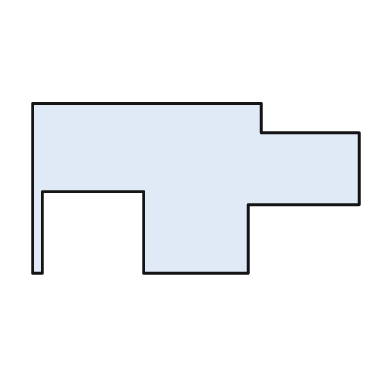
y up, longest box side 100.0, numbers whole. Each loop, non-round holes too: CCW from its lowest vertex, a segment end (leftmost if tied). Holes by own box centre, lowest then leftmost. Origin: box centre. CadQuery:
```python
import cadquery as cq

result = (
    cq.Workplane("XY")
    .moveTo(-50.0, -26.0)
    .lineTo(-47.0, -26.0)
    .lineTo(-47.0, -1.0)
    .lineTo(-16.0, -1.0)
    .lineTo(-16.0, -26.0)
    .lineTo(16.0, -26.0)
    .lineTo(16.0, -5.0)
    .lineTo(50.0, -5.0)
    .lineTo(50.0, 17.0)
    .lineTo(20.0, 17.0)
    .lineTo(20.0, 26.0)
    .lineTo(-50.0, 26.0)
    .close()
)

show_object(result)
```